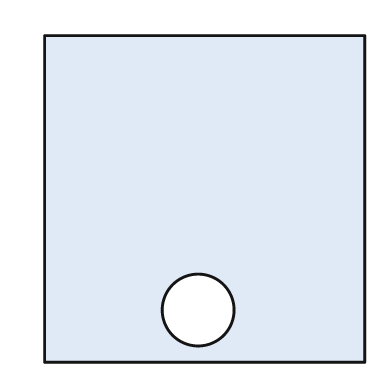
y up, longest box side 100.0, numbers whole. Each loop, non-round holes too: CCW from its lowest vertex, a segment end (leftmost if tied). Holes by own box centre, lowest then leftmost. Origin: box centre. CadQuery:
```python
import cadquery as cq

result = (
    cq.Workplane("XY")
    .moveTo(-49.0, -50.0)
    .lineTo(49.0, -50.0)
    .lineTo(49.0, 50.0)
    .lineTo(-49.0, 50.0)
    .close()
    .moveTo(-2.0, -34.0)
    .circle(11.0)
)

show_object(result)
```